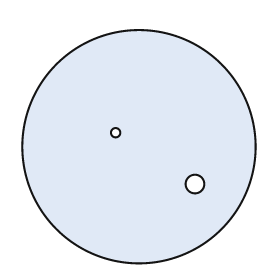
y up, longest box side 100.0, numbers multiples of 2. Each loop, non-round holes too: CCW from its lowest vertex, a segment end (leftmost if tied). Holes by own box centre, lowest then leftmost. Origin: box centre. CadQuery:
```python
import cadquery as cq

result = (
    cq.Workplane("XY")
    .moveTo(0.0, 0.0)
    .circle(50.0)
    .moveTo(24.0, -16.0)
    .circle(4.0)
    .moveTo(-10.0, 6.0)
    .circle(2.0)
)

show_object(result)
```